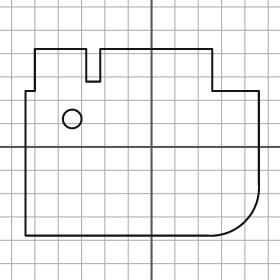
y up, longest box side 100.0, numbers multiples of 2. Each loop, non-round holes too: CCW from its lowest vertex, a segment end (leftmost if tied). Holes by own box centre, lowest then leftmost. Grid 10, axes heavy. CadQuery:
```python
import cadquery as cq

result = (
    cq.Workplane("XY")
    .moveTo(-54.0, -38.0)
    .lineTo(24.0, -38.0)
    .threePointArc((40.0, -32.0), (46.0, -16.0))
    .lineTo(46.0, 24.0)
    .lineTo(26.0, 24.0)
    .lineTo(26.0, 42.0)
    .lineTo(-22.0, 42.0)
    .lineTo(-22.0, 28.0)
    .lineTo(-28.0, 28.0)
    .lineTo(-28.0, 42.0)
    .lineTo(-50.0, 42.0)
    .lineTo(-50.0, 24.0)
    .lineTo(-54.0, 24.0)
    .close()
    .moveTo(-34.0, 12.0)
    .circle(4.0)
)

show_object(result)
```